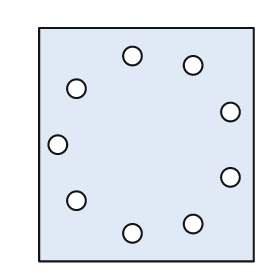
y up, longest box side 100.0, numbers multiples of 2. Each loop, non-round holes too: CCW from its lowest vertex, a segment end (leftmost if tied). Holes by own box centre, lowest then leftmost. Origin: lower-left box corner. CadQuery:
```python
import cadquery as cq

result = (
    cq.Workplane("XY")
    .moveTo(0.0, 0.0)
    .lineTo(92.0, 0.0)
    .lineTo(92.0, 100.0)
    .lineTo(0.0, 100.0)
    .close()
    .moveTo(40.0, 12.0)
    .circle(4.0)
    .moveTo(66.0, 16.0)
    .circle(4.0)
    .moveTo(16.0, 26.0)
    .circle(4.0)
    .moveTo(82.0, 36.0)
    .circle(4.0)
    .moveTo(8.0, 50.0)
    .circle(4.0)
    .moveTo(82.0, 64.0)
    .circle(4.0)
    .moveTo(16.0, 74.0)
    .circle(4.0)
    .moveTo(66.0, 84.0)
    .circle(4.0)
    .moveTo(40.0, 88.0)
    .circle(4.0)
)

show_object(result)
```